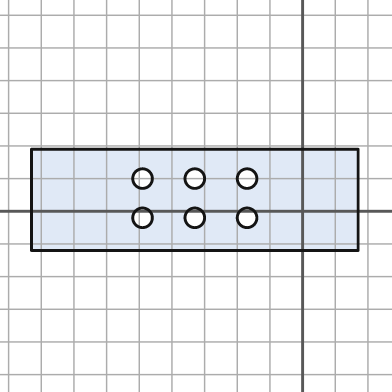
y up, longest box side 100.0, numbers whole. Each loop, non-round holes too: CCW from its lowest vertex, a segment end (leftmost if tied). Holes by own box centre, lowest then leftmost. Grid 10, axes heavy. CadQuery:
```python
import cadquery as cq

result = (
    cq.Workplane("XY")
    .moveTo(-83.0, -12.0)
    .lineTo(17.0, -12.0)
    .lineTo(17.0, 19.0)
    .lineTo(-83.0, 19.0)
    .close()
    .moveTo(-49.0, -2.0)
    .circle(3.0)
    .moveTo(-33.0, -2.0)
    .circle(3.0)
    .moveTo(-17.0, -2.0)
    .circle(3.0)
    .moveTo(-49.0, 10.0)
    .circle(3.0)
    .moveTo(-33.0, 10.0)
    .circle(3.0)
    .moveTo(-17.0, 10.0)
    .circle(3.0)
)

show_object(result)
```